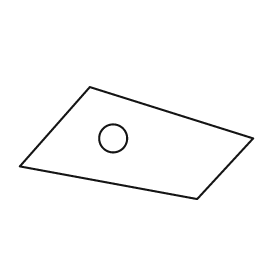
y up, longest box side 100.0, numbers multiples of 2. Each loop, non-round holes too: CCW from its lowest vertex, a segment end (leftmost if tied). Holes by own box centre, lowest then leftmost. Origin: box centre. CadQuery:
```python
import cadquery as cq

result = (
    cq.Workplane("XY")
    .moveTo(26.0, -24.0)
    .lineTo(50.0, 2.0)
    .lineTo(-20.0, 24.0)
    .lineTo(-50.0, -10.0)
    .close()
    .moveTo(-10.0, 2.0)
    .circle(6.0)
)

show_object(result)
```